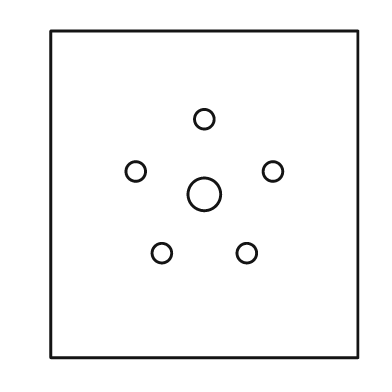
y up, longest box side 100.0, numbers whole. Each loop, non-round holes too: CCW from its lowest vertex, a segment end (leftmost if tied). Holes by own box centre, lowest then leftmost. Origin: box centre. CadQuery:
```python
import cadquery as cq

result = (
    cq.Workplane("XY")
    .moveTo(-47.0, -50.0)
    .lineTo(47.0, -50.0)
    .lineTo(47.0, 50.0)
    .lineTo(-47.0, 50.0)
    .close()
    .moveTo(-13.0, -18.0)
    .circle(3.0)
    .moveTo(13.0, -18.0)
    .circle(3.0)
    .moveTo(0.0, 0.0)
    .circle(5.0)
    .moveTo(-21.0, 7.0)
    .circle(3.0)
    .moveTo(21.0, 7.0)
    .circle(3.0)
    .moveTo(0.0, 23.0)
    .circle(3.0)
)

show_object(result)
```